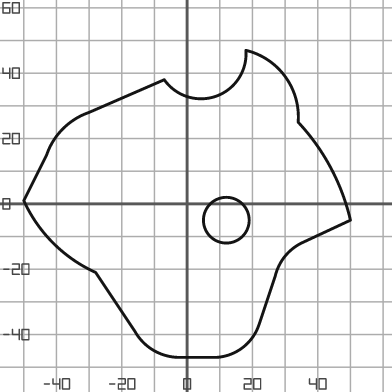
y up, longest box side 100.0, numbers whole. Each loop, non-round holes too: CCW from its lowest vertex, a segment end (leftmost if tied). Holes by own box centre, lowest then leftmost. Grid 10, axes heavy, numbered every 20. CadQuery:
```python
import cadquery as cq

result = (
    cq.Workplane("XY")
    .moveTo(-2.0, -47.0)
    .lineTo(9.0, -47.0)
    .threePointArc((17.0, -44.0), (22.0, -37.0))
    .lineTo(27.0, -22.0)
    .threePointArc((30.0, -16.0), (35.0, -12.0))
    .lineTo(50.0, -5.0)
    .threePointArc((44.0, 11.0), (34.0, 25.0))
    .threePointArc((30.0, 39.0), (18.0, 47.0))
    .threePointArc((9.0, 33.0), (-7.0, 38.0))
    .lineTo(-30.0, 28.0)
    .threePointArc((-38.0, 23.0), (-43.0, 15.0))
    .lineTo(-50.0, 1.0)
    .threePointArc((-41.0, -12.0), (-28.0, -21.0))
    .lineTo(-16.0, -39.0)
    .threePointArc((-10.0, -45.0), (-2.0, -47.0))
    .close()
    .moveTo(12.0, -5.0)
    .circle(7.0)
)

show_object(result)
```